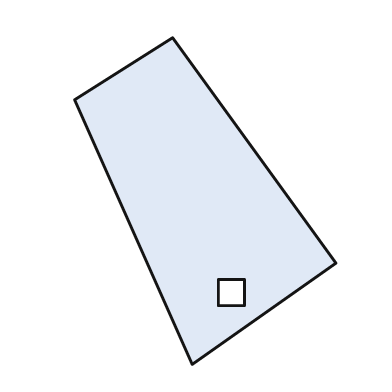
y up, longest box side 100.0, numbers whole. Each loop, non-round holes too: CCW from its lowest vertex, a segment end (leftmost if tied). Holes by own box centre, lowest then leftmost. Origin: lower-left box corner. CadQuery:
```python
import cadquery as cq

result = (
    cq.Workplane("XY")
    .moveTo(36.0, 0.0)
    .lineTo(80.0, 31.0)
    .lineTo(30.0, 100.0)
    .lineTo(0.0, 81.0)
    .close()
    .moveTo(44.0, 18.0)
    .lineTo(52.0, 18.0)
    .lineTo(52.0, 26.0)
    .lineTo(44.0, 26.0)
    .close()
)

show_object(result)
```